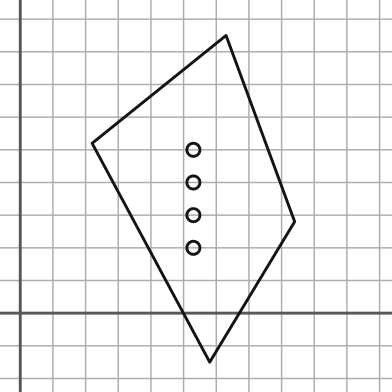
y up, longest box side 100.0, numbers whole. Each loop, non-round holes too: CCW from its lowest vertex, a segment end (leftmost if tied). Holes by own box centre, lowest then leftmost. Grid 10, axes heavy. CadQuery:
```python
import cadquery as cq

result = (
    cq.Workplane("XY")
    .moveTo(58.0, -15.0)
    .lineTo(84.0, 28.0)
    .lineTo(63.0, 85.0)
    .lineTo(22.0, 52.0)
    .close()
    .moveTo(53.0, 20.0)
    .circle(2.0)
    .moveTo(53.0, 30.0)
    .circle(2.0)
    .moveTo(53.0, 40.0)
    .circle(2.0)
    .moveTo(53.0, 50.0)
    .circle(2.0)
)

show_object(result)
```